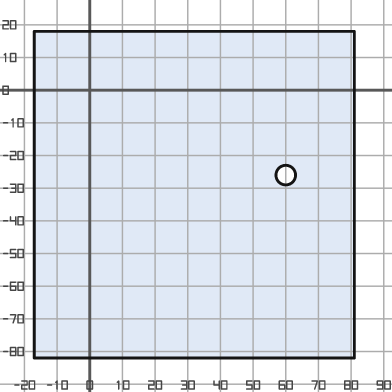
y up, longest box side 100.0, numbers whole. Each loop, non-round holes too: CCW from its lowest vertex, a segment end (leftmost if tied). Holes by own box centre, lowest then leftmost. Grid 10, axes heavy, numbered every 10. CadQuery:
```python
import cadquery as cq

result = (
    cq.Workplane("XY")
    .moveTo(-17.0, -82.0)
    .lineTo(81.0, -82.0)
    .lineTo(81.0, 18.0)
    .lineTo(-17.0, 18.0)
    .close()
    .moveTo(60.0, -26.0)
    .circle(3.0)
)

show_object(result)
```